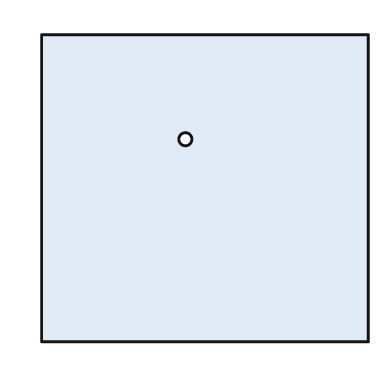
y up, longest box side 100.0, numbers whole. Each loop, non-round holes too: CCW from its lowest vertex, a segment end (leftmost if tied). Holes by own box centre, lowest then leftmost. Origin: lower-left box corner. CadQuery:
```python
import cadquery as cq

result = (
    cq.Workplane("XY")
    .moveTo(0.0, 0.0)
    .lineTo(100.0, 0.0)
    .lineTo(100.0, 94.0)
    .lineTo(0.0, 94.0)
    .close()
    .moveTo(44.0, 62.0)
    .circle(2.0)
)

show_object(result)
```